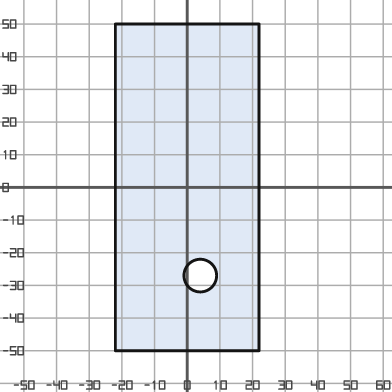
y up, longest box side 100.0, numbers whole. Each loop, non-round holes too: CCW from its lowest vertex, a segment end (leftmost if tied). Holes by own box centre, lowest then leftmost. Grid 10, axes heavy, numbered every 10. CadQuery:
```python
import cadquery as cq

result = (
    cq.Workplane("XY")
    .moveTo(-22.0, -50.0)
    .lineTo(22.0, -50.0)
    .lineTo(22.0, 50.0)
    .lineTo(-22.0, 50.0)
    .close()
    .moveTo(4.0, -27.0)
    .circle(5.0)
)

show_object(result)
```